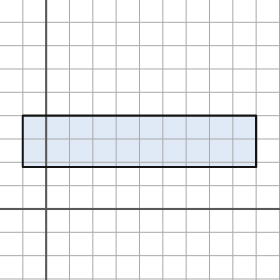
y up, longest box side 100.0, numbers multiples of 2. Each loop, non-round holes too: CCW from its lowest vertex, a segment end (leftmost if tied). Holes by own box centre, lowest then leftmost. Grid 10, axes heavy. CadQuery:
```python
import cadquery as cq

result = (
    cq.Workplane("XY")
    .moveTo(-10.0, 18.0)
    .lineTo(90.0, 18.0)
    .lineTo(90.0, 40.0)
    .lineTo(-10.0, 40.0)
    .close()
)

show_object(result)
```